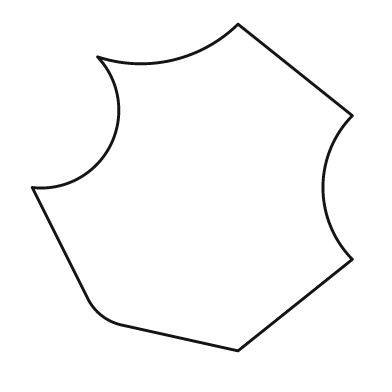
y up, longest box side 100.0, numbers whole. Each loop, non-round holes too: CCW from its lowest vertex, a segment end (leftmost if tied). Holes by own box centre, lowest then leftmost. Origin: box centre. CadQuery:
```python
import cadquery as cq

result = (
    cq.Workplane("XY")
    .moveTo(14.0, -50.0)
    .lineTo(49.0, -22.0)
    .threePointArc((40.0, 0.0), (49.0, 22.0))
    .lineTo(14.0, 50.0)
    .threePointArc((-6.0, 39.0), (-29.0, 40.0))
    .threePointArc((-25.0, 13.0), (-49.0, 0.0))
    .lineTo(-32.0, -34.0)
    .threePointArc((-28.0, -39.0), (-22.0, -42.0))
    .close()
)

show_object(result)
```